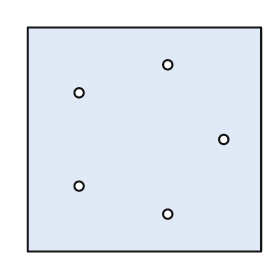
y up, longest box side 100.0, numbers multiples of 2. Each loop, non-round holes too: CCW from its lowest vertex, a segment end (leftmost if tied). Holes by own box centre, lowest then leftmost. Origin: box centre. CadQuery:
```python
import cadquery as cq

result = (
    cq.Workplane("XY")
    .moveTo(-50.0, -48.0)
    .lineTo(50.0, -48.0)
    .lineTo(50.0, 48.0)
    .lineTo(-50.0, 48.0)
    .close()
    .moveTo(10.0, -32.0)
    .circle(2.0)
    .moveTo(-28.0, -20.0)
    .circle(2.0)
    .moveTo(34.0, 0.0)
    .circle(2.0)
    .moveTo(-28.0, 20.0)
    .circle(2.0)
    .moveTo(10.0, 32.0)
    .circle(2.0)
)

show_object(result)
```